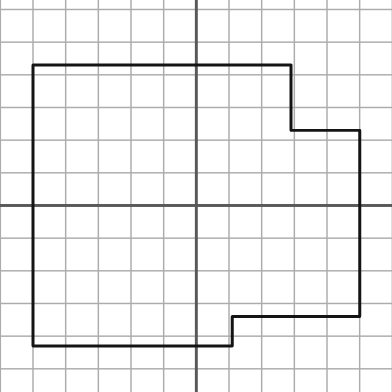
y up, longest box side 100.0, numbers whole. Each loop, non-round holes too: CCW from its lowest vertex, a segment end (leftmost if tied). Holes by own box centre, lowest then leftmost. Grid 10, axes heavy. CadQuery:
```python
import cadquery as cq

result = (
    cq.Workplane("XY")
    .moveTo(-50.0, -43.0)
    .lineTo(11.0, -43.0)
    .lineTo(11.0, -34.0)
    .lineTo(50.0, -34.0)
    .lineTo(50.0, 23.0)
    .lineTo(29.0, 23.0)
    .lineTo(29.0, 43.0)
    .lineTo(-50.0, 43.0)
    .close()
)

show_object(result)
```